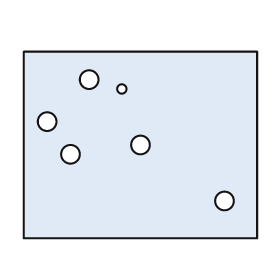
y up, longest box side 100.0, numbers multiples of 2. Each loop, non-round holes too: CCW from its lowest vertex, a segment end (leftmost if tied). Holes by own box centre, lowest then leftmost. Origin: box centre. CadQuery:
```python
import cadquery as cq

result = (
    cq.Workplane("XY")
    .moveTo(-50.0, -40.0)
    .lineTo(50.0, -40.0)
    .lineTo(50.0, 40.0)
    .lineTo(-50.0, 40.0)
    .close()
    .moveTo(36.0, -24.0)
    .circle(4.0)
    .moveTo(-30.0, -4.0)
    .circle(4.0)
    .moveTo(0.0, 0.0)
    .circle(4.0)
    .moveTo(-40.0, 10.0)
    .circle(4.0)
    .moveTo(-8.0, 24.0)
    .circle(2.0)
    .moveTo(-22.0, 28.0)
    .circle(4.0)
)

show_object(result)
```